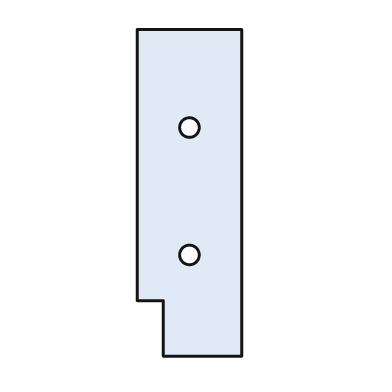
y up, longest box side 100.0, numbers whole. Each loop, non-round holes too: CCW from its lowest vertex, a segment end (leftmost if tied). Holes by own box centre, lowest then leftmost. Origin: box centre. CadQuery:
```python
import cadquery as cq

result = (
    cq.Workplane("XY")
    .moveTo(-8.0, -50.0)
    .lineTo(16.0, -50.0)
    .lineTo(16.0, 50.0)
    .lineTo(-16.0, 50.0)
    .lineTo(-16.0, -33.0)
    .lineTo(-8.0, -33.0)
    .close()
    .moveTo(0.0, -19.0)
    .circle(3.0)
    .moveTo(0.0, 20.0)
    .circle(3.0)
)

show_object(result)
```